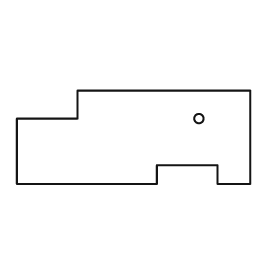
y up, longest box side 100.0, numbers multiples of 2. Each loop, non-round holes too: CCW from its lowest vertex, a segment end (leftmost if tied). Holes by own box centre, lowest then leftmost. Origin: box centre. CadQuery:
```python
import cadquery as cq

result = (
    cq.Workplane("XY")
    .moveTo(-50.0, -20.0)
    .lineTo(10.0, -20.0)
    .lineTo(10.0, -12.0)
    .lineTo(36.0, -12.0)
    .lineTo(36.0, -20.0)
    .lineTo(50.0, -20.0)
    .lineTo(50.0, 20.0)
    .lineTo(-24.0, 20.0)
    .lineTo(-24.0, 8.0)
    .lineTo(-50.0, 8.0)
    .close()
    .moveTo(28.0, 8.0)
    .circle(2.0)
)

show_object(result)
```